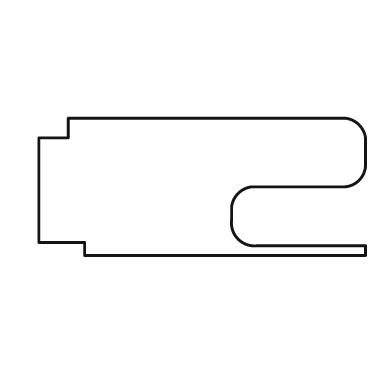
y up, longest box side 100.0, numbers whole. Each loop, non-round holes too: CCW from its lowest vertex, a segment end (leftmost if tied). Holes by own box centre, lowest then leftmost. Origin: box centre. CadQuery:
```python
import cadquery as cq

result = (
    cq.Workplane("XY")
    .moveTo(-36.0, -21.0)
    .lineTo(50.0, -21.0)
    .lineTo(50.0, -18.0)
    .lineTo(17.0, -18.0)
    .threePointArc((11.0, -16.0), (9.0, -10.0))
    .lineTo(9.0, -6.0)
    .threePointArc((11.0, -2.0), (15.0, 0.0))
    .lineTo(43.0, 0.0)
    .threePointArc((48.0, 2.0), (50.0, 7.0))
    .lineTo(50.0, 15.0)
    .threePointArc((48.0, 19.0), (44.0, 21.0))
    .lineTo(-41.0, 21.0)
    .lineTo(-41.0, 15.0)
    .lineTo(-50.0, 15.0)
    .lineTo(-50.0, -17.0)
    .lineTo(-36.0, -17.0)
    .close()
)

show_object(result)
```